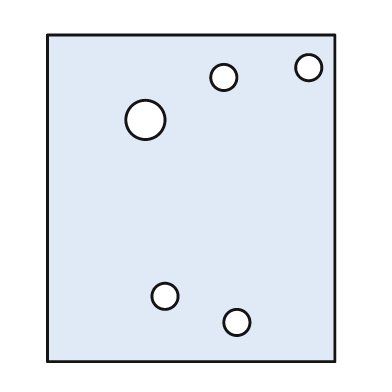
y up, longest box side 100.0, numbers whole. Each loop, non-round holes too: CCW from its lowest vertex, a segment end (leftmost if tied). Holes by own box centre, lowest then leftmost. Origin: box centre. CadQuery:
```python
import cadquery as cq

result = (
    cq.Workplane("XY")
    .moveTo(-44.0, -50.0)
    .lineTo(44.0, -50.0)
    .lineTo(44.0, 50.0)
    .lineTo(-44.0, 50.0)
    .close()
    .moveTo(14.0, -38.0)
    .circle(4.0)
    .moveTo(-8.0, -30.0)
    .circle(4.0)
    .moveTo(-14.0, 24.0)
    .circle(6.0)
    .moveTo(10.0, 37.0)
    .circle(4.0)
    .moveTo(36.0, 40.0)
    .circle(4.0)
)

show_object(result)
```